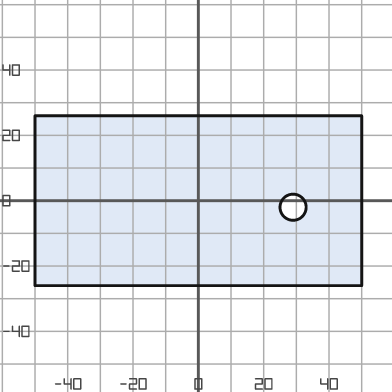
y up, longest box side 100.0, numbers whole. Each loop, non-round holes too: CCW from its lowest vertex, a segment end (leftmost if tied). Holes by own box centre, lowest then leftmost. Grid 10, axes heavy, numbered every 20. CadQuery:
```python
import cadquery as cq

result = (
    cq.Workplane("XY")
    .moveTo(-50.0, -26.0)
    .lineTo(50.0, -26.0)
    .lineTo(50.0, 26.0)
    .lineTo(-50.0, 26.0)
    .close()
    .moveTo(29.0, -2.0)
    .circle(4.0)
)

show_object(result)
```